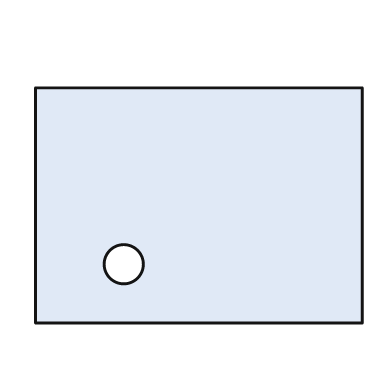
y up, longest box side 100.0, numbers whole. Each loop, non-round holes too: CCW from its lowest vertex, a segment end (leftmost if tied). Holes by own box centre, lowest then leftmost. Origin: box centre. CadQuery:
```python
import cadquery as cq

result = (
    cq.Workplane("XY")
    .moveTo(-50.0, -36.0)
    .lineTo(50.0, -36.0)
    .lineTo(50.0, 36.0)
    .lineTo(-50.0, 36.0)
    .close()
    .moveTo(-23.0, -18.0)
    .circle(6.0)
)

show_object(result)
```